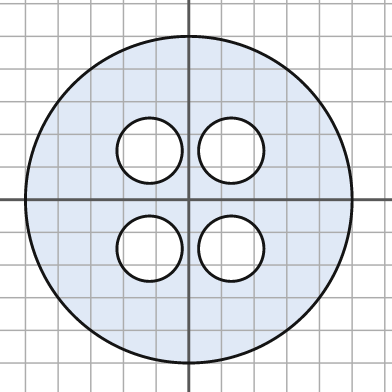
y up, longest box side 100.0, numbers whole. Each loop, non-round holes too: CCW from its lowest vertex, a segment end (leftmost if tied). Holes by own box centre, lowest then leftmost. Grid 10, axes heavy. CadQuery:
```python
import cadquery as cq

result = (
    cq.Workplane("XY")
    .moveTo(0.0, 0.0)
    .circle(50.0)
    .moveTo(-12.0, -15.0)
    .circle(10.0)
    .moveTo(13.0, -15.0)
    .circle(10.0)
    .moveTo(-12.0, 15.0)
    .circle(10.0)
    .moveTo(13.0, 15.0)
    .circle(10.0)
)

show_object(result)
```